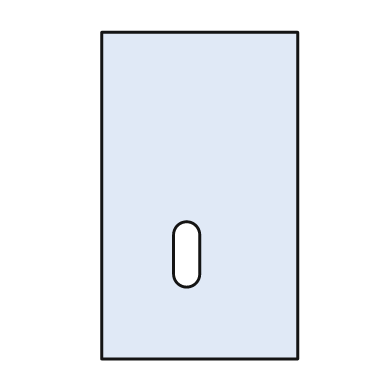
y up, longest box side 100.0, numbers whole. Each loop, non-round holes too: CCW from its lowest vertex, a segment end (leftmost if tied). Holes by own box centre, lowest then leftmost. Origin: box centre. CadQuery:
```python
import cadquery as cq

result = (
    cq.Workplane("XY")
    .moveTo(-30.0, -50.0)
    .lineTo(30.0, -50.0)
    .lineTo(30.0, 50.0)
    .lineTo(-30.0, 50.0)
    .close()
    .moveTo(-8.0, -24.0)
    .threePointArc((-4.0, -28.0), (0.0, -24.0))
    .lineTo(0.0, -12.0)
    .threePointArc((-4.0, -8.0), (-8.0, -12.0))
    .close()
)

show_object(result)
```